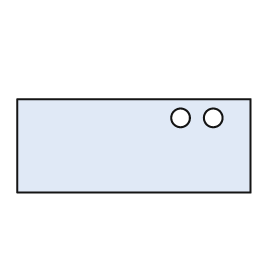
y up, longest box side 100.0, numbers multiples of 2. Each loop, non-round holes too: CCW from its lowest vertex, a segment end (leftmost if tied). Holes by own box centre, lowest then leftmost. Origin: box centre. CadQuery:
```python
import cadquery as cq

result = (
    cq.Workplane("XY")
    .moveTo(-50.0, -20.0)
    .lineTo(50.0, -20.0)
    .lineTo(50.0, 20.0)
    .lineTo(-50.0, 20.0)
    .close()
    .moveTo(20.0, 12.0)
    .circle(4.0)
    .moveTo(34.0, 12.0)
    .circle(4.0)
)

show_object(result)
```